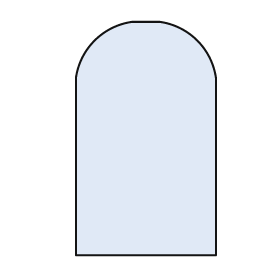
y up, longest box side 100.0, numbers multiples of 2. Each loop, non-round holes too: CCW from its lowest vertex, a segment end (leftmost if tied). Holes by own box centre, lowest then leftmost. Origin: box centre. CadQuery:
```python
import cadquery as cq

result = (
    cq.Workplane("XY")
    .moveTo(-30.0, -50.0)
    .lineTo(30.0, -50.0)
    .lineTo(30.0, 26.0)
    .threePointArc((22.0, 42.0), (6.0, 50.0))
    .lineTo(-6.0, 50.0)
    .threePointArc((-22.0, 42.0), (-30.0, 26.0))
    .close()
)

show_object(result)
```